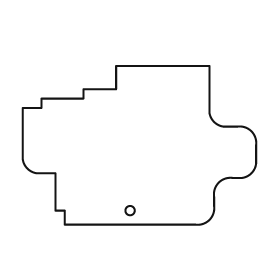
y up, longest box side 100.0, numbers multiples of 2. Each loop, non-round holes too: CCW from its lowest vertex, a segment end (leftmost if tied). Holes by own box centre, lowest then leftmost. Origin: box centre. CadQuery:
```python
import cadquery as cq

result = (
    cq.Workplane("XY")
    .moveTo(-32.0, -34.0)
    .lineTo(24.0, -34.0)
    .threePointArc((30.0, -32.0), (32.0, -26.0))
    .lineTo(32.0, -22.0)
    .threePointArc((34.0, -16.0), (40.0, -14.0))
    .lineTo(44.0, -14.0)
    .threePointArc((48.0, -12.0), (50.0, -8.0))
    .lineTo(50.0, 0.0)
    .threePointArc((48.0, 6.0), (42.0, 8.0))
    .lineTo(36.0, 8.0)
    .threePointArc((32.0, 10.0), (30.0, 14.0))
    .lineTo(30.0, 34.0)
    .lineTo(-10.0, 34.0)
    .lineTo(-10.0, 24.0)
    .lineTo(-24.0, 24.0)
    .lineTo(-24.0, 20.0)
    .lineTo(-42.0, 20.0)
    .lineTo(-42.0, 16.0)
    .lineTo(-50.0, 16.0)
    .lineTo(-50.0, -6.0)
    .threePointArc((-48.0, -10.0), (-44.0, -12.0))
    .lineTo(-36.0, -12.0)
    .lineTo(-36.0, -28.0)
    .lineTo(-32.0, -28.0)
    .close()
    .moveTo(-4.0, -28.0)
    .circle(2.0)
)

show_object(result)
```